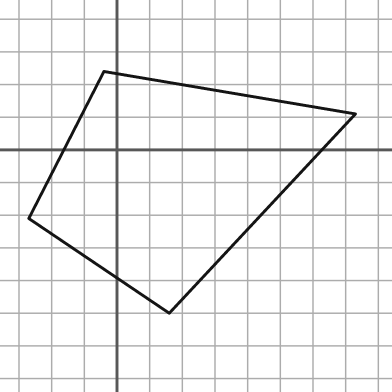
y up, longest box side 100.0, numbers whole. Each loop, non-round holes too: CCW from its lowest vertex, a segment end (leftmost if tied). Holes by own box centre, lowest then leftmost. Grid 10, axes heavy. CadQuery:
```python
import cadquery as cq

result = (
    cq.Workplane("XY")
    .moveTo(16.0, -50.0)
    .lineTo(73.0, 11.0)
    .lineTo(-4.0, 24.0)
    .lineTo(-27.0, -21.0)
    .close()
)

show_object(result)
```